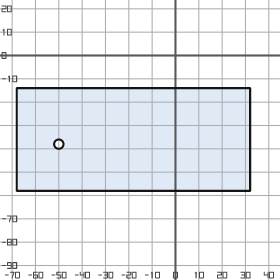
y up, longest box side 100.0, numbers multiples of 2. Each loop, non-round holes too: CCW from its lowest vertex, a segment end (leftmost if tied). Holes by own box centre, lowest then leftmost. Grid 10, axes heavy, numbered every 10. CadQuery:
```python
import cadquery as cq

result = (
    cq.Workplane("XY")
    .moveTo(-68.0, -58.0)
    .lineTo(32.0, -58.0)
    .lineTo(32.0, -14.0)
    .lineTo(-68.0, -14.0)
    .close()
    .moveTo(-50.0, -38.0)
    .circle(2.0)
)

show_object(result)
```